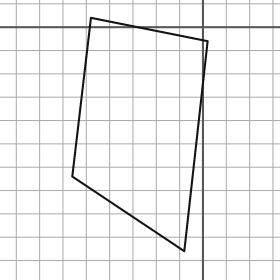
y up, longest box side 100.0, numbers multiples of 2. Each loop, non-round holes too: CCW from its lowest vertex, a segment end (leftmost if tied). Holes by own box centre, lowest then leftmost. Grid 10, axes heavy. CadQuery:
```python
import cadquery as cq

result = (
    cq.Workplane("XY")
    .moveTo(-8.0, -96.0)
    .lineTo(2.0, -6.0)
    .lineTo(-48.0, 4.0)
    .lineTo(-56.0, -64.0)
    .close()
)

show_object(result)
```